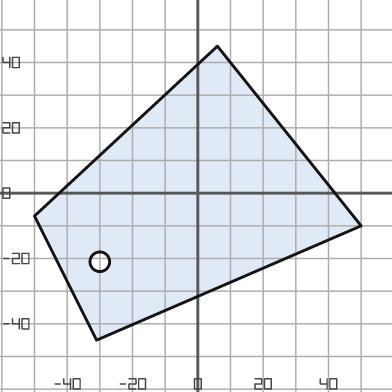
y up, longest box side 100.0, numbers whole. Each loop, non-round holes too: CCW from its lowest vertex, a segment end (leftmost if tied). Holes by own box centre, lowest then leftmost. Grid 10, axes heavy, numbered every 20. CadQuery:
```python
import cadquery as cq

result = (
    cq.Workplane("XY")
    .moveTo(-31.0, -45.0)
    .lineTo(50.0, -10.0)
    .lineTo(6.0, 45.0)
    .lineTo(-50.0, -7.0)
    .close()
    .moveTo(-30.0, -21.0)
    .circle(3.0)
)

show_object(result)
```